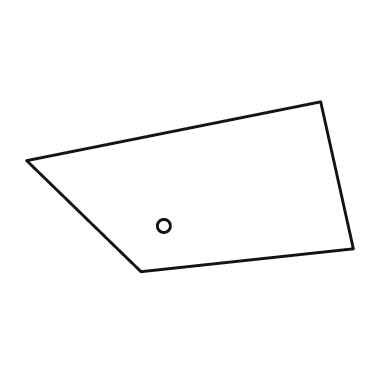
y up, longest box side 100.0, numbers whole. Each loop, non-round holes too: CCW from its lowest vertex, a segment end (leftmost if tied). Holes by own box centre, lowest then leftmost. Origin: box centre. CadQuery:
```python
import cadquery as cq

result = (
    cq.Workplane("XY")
    .moveTo(-15.0, -26.0)
    .lineTo(50.0, -19.0)
    .lineTo(40.0, 26.0)
    .lineTo(-50.0, 8.0)
    .close()
    .moveTo(-8.0, -12.0)
    .circle(2.0)
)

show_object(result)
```